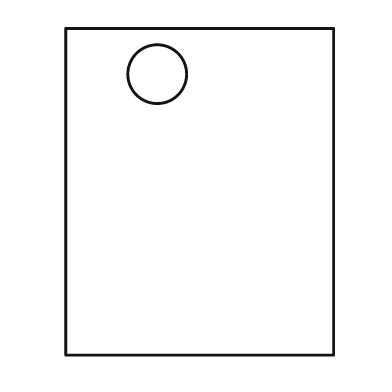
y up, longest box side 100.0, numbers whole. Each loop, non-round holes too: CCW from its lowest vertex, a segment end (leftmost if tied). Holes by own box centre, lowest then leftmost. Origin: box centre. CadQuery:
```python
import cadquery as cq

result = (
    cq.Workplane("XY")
    .moveTo(-41.0, -50.0)
    .lineTo(41.0, -50.0)
    .lineTo(41.0, 50.0)
    .lineTo(-41.0, 50.0)
    .close()
    .moveTo(-13.0, 36.0)
    .circle(9.0)
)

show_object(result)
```